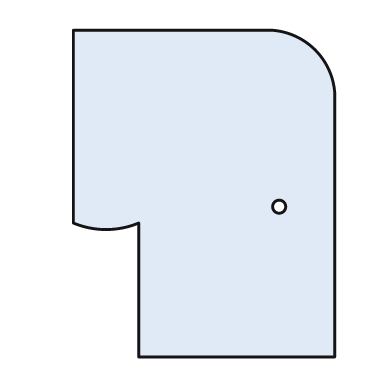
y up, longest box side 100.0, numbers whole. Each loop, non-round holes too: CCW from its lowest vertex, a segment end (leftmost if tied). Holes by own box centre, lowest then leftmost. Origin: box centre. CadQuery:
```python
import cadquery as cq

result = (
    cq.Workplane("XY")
    .moveTo(-20.0, -50.0)
    .lineTo(40.0, -50.0)
    .lineTo(40.0, 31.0)
    .threePointArc((34.0, 44.0), (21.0, 50.0))
    .lineTo(-40.0, 50.0)
    .lineTo(-40.0, -9.0)
    .threePointArc((-30.0, -11.0), (-20.0, -9.0))
    .close()
    .moveTo(23.0, -4.0)
    .circle(2.0)
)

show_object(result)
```